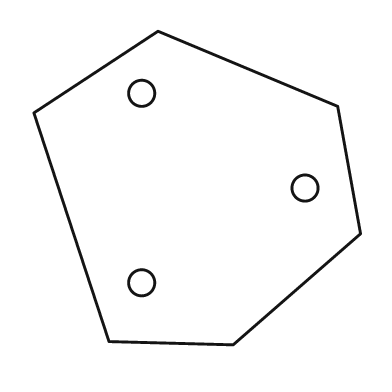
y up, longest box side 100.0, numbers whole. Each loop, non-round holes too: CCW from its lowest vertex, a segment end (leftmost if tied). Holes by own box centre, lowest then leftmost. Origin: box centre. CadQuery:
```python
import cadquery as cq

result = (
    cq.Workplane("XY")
    .moveTo(11.0, -48.0)
    .lineTo(50.0, -14.0)
    .lineTo(43.0, 25.0)
    .lineTo(-12.0, 48.0)
    .lineTo(-50.0, 23.0)
    .lineTo(-27.0, -47.0)
    .close()
    .moveTo(-17.0, -29.0)
    .circle(4.0)
    .moveTo(33.0, 0.0)
    .circle(4.0)
    .moveTo(-17.0, 29.0)
    .circle(4.0)
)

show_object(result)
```